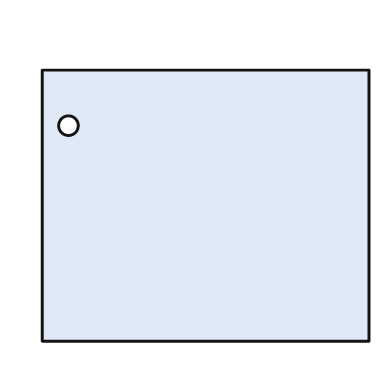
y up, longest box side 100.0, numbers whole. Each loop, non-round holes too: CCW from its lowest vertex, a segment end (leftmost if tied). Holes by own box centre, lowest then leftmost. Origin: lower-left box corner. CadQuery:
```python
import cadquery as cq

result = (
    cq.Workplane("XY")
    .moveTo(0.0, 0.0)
    .lineTo(100.0, 0.0)
    .lineTo(100.0, 83.0)
    .lineTo(0.0, 83.0)
    .close()
    .moveTo(8.0, 66.0)
    .circle(3.0)
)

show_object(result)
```